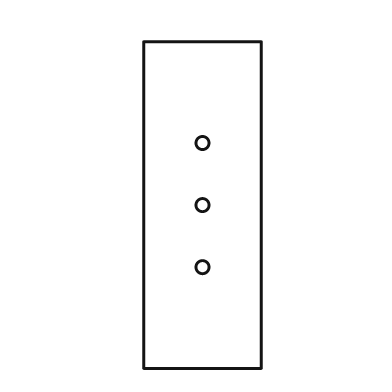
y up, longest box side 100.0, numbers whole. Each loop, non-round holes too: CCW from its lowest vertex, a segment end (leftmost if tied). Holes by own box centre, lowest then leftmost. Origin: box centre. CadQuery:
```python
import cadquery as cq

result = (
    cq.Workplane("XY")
    .moveTo(-18.0, -50.0)
    .lineTo(18.0, -50.0)
    .lineTo(18.0, 50.0)
    .lineTo(-18.0, 50.0)
    .close()
    .moveTo(0.0, -19.0)
    .circle(2.0)
    .moveTo(0.0, 0.0)
    .circle(2.0)
    .moveTo(0.0, 19.0)
    .circle(2.0)
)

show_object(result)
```